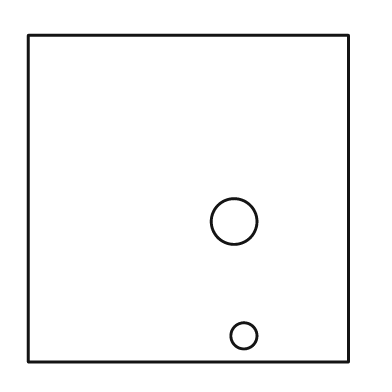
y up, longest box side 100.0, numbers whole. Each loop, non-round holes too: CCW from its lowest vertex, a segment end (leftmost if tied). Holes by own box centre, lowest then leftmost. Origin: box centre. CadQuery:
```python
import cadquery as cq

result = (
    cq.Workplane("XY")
    .moveTo(-49.0, -50.0)
    .lineTo(49.0, -50.0)
    .lineTo(49.0, 50.0)
    .lineTo(-49.0, 50.0)
    .close()
    .moveTo(17.0, -42.0)
    .circle(4.0)
    .moveTo(14.0, -7.0)
    .circle(7.0)
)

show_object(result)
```